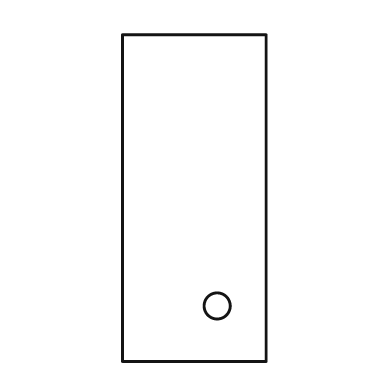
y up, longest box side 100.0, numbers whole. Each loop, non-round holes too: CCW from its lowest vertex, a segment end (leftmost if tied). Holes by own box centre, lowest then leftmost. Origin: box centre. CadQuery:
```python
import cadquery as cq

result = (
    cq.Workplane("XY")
    .moveTo(-22.0, -50.0)
    .lineTo(22.0, -50.0)
    .lineTo(22.0, 50.0)
    .lineTo(-22.0, 50.0)
    .close()
    .moveTo(7.0, -33.0)
    .circle(4.0)
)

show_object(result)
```